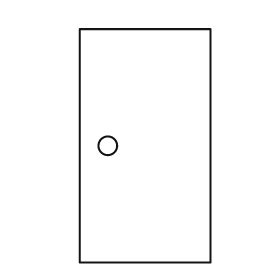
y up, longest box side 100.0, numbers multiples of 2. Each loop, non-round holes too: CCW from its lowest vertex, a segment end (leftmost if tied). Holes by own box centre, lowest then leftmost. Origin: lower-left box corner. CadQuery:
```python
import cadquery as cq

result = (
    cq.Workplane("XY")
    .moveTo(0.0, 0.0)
    .lineTo(56.0, 0.0)
    .lineTo(56.0, 100.0)
    .lineTo(0.0, 100.0)
    .close()
    .moveTo(12.0, 50.0)
    .circle(4.0)
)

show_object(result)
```